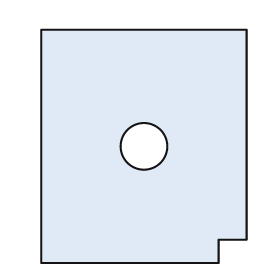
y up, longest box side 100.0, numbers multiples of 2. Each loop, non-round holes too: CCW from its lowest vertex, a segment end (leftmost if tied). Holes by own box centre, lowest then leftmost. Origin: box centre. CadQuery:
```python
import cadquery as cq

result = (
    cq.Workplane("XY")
    .moveTo(-44.0, -50.0)
    .lineTo(32.0, -50.0)
    .lineTo(32.0, -40.0)
    .lineTo(44.0, -40.0)
    .lineTo(44.0, 50.0)
    .lineTo(-44.0, 50.0)
    .close()
    .moveTo(0.0, 0.0)
    .circle(10.0)
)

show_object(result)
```